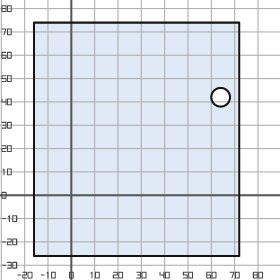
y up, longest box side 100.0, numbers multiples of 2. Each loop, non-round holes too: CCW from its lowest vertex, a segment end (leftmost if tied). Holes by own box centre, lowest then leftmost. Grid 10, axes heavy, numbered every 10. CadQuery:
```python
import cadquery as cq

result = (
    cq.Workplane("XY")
    .moveTo(-16.0, -26.0)
    .lineTo(72.0, -26.0)
    .lineTo(72.0, 74.0)
    .lineTo(-16.0, 74.0)
    .close()
    .moveTo(64.0, 42.0)
    .circle(4.0)
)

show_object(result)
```